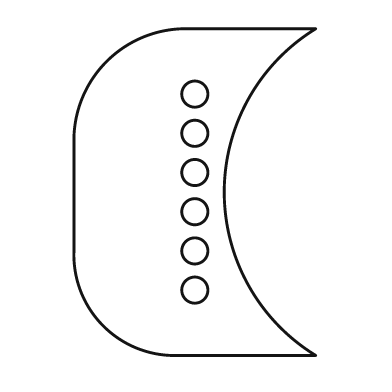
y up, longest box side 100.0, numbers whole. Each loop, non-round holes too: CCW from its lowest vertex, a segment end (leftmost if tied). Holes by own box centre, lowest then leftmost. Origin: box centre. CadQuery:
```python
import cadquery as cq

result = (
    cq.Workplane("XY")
    .moveTo(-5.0, -50.0)
    .lineTo(37.0, -50.0)
    .threePointArc((9.0, 0.0), (37.0, 50.0))
    .lineTo(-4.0, 50.0)
    .threePointArc((-27.0, 40.0), (-37.0, 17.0))
    .lineTo(-37.0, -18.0)
    .threePointArc((-28.0, -41.0), (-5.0, -50.0))
    .close()
    .moveTo(0.0, -30.0)
    .circle(4.0)
    .moveTo(0.0, -18.0)
    .circle(4.0)
    .moveTo(0.0, -6.0)
    .circle(4.0)
    .moveTo(0.0, 6.0)
    .circle(4.0)
    .moveTo(0.0, 18.0)
    .circle(4.0)
    .moveTo(0.0, 30.0)
    .circle(4.0)
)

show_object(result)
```